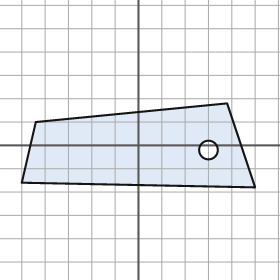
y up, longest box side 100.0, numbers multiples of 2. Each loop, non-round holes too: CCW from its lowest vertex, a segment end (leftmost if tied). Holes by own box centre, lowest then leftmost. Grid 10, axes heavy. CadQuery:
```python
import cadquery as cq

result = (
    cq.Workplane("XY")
    .moveTo(50.0, -18.0)
    .lineTo(38.0, 18.0)
    .lineTo(-44.0, 10.0)
    .lineTo(-50.0, -16.0)
    .close()
    .moveTo(30.0, -2.0)
    .circle(4.0)
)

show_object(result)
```